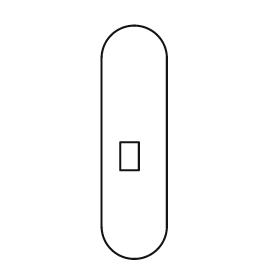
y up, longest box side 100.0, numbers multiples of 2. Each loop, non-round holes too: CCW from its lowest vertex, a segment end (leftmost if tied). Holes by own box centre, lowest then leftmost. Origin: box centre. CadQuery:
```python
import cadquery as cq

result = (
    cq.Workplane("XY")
    .moveTo(-14.0, -36.0)
    .threePointArc((0.0, -50.0), (14.0, -36.0))
    .lineTo(14.0, 36.0)
    .threePointArc((0.0, 50.0), (-14.0, 36.0))
    .close()
    .moveTo(-6.0, -12.0)
    .lineTo(2.0, -12.0)
    .lineTo(2.0, 0.0)
    .lineTo(-6.0, 0.0)
    .close()
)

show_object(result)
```